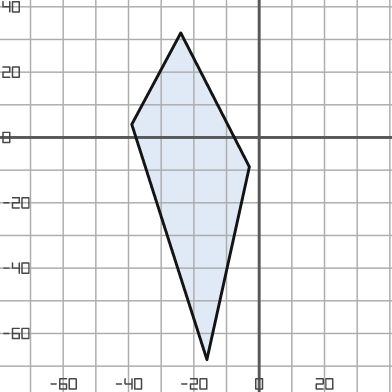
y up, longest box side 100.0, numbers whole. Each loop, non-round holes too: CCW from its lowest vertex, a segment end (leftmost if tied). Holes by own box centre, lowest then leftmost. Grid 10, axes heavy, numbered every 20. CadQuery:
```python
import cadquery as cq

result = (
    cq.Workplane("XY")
    .moveTo(-16.0, -68.0)
    .lineTo(-3.0, -9.0)
    .lineTo(-24.0, 32.0)
    .lineTo(-39.0, 4.0)
    .close()
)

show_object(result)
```